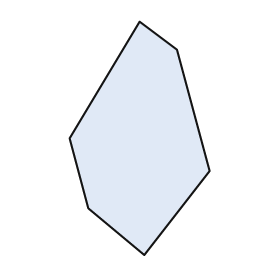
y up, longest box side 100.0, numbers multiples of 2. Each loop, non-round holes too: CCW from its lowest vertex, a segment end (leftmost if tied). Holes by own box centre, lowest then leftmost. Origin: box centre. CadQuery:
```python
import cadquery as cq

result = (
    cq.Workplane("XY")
    .moveTo(2.0, -50.0)
    .lineTo(30.0, -14.0)
    .lineTo(16.0, 38.0)
    .lineTo(0.0, 50.0)
    .lineTo(-30.0, 0.0)
    .lineTo(-22.0, -30.0)
    .close()
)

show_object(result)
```